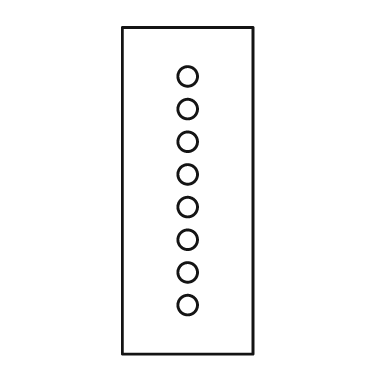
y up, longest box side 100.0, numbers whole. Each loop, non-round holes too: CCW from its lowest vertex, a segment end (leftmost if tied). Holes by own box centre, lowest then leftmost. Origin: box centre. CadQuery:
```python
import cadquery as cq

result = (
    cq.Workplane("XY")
    .moveTo(-20.0, -50.0)
    .lineTo(20.0, -50.0)
    .lineTo(20.0, 50.0)
    .lineTo(-20.0, 50.0)
    .close()
    .moveTo(0.0, -35.0)
    .circle(3.0)
    .moveTo(0.0, -25.0)
    .circle(3.0)
    .moveTo(0.0, -15.0)
    .circle(3.0)
    .moveTo(0.0, -5.0)
    .circle(3.0)
    .moveTo(0.0, 5.0)
    .circle(3.0)
    .moveTo(0.0, 15.0)
    .circle(3.0)
    .moveTo(0.0, 25.0)
    .circle(3.0)
    .moveTo(0.0, 35.0)
    .circle(3.0)
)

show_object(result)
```